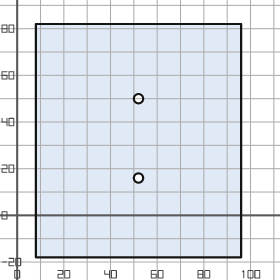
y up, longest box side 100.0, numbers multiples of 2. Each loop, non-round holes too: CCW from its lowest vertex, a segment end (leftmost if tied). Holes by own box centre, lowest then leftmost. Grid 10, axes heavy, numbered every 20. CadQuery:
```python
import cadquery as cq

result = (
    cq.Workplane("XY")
    .moveTo(8.0, -18.0)
    .lineTo(96.0, -18.0)
    .lineTo(96.0, 82.0)
    .lineTo(8.0, 82.0)
    .close()
    .moveTo(52.0, 16.0)
    .circle(2.0)
    .moveTo(52.0, 50.0)
    .circle(2.0)
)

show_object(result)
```